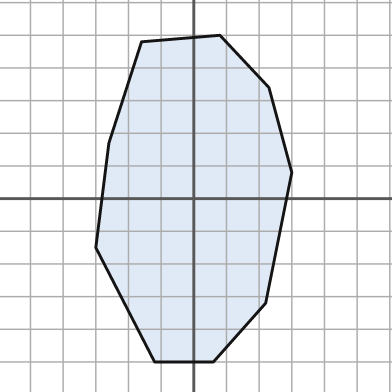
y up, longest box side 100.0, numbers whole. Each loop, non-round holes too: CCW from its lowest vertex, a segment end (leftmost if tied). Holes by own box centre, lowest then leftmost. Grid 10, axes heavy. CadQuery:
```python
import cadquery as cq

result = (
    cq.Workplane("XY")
    .moveTo(-12.0, -50.0)
    .lineTo(6.0, -50.0)
    .lineTo(22.0, -32.0)
    .lineTo(30.0, 8.0)
    .lineTo(23.0, 34.0)
    .lineTo(8.0, 50.0)
    .lineTo(-16.0, 48.0)
    .lineTo(-26.0, 17.0)
    .lineTo(-30.0, -15.0)
    .close()
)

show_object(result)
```